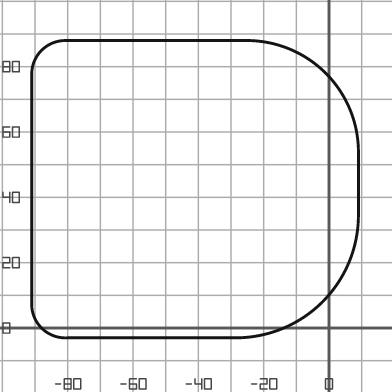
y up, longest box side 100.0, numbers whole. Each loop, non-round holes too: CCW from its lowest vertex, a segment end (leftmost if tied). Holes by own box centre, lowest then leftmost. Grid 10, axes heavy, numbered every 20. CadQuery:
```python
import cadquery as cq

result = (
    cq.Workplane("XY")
    .moveTo(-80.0, -3.0)
    .lineTo(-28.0, -3.0)
    .threePointArc((-2.0, 8.0), (9.0, 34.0))
    .lineTo(9.0, 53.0)
    .threePointArc((-1.0, 78.0), (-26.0, 88.0))
    .lineTo(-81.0, 88.0)
    .threePointArc((-88.0, 85.0), (-91.0, 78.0))
    .lineTo(-91.0, 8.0)
    .threePointArc((-88.0, 0.0), (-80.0, -3.0))
    .close()
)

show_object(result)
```